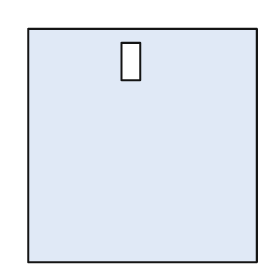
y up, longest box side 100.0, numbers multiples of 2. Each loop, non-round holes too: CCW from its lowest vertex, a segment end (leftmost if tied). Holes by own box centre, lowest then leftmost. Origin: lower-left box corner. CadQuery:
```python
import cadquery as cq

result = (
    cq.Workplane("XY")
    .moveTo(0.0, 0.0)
    .lineTo(98.0, 0.0)
    .lineTo(98.0, 100.0)
    .lineTo(0.0, 100.0)
    .close()
    .moveTo(40.0, 78.0)
    .lineTo(48.0, 78.0)
    .lineTo(48.0, 94.0)
    .lineTo(40.0, 94.0)
    .close()
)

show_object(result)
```